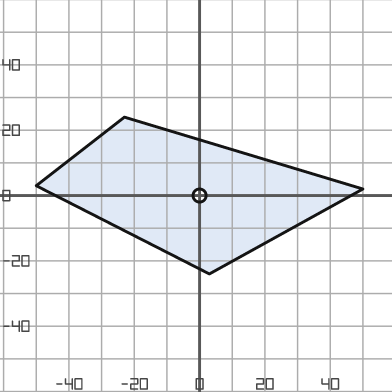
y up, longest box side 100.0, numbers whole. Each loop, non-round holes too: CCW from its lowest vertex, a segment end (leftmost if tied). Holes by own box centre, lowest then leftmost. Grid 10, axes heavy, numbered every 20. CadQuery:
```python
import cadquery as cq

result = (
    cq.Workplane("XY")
    .moveTo(3.0, -24.0)
    .lineTo(50.0, 2.0)
    .lineTo(-23.0, 24.0)
    .lineTo(-50.0, 3.0)
    .close()
    .moveTo(0.0, 0.0)
    .circle(2.0)
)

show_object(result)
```